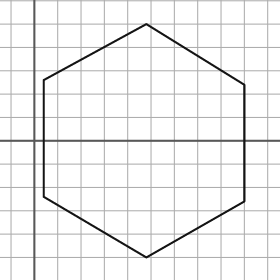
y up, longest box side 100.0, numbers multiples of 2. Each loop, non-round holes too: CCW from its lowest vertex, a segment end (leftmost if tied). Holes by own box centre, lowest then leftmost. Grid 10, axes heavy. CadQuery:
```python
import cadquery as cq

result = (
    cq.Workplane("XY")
    .moveTo(48.0, -50.0)
    .lineTo(90.0, -26.0)
    .lineTo(90.0, 24.0)
    .lineTo(48.0, 50.0)
    .lineTo(4.0, 26.0)
    .lineTo(4.0, -24.0)
    .close()
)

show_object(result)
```